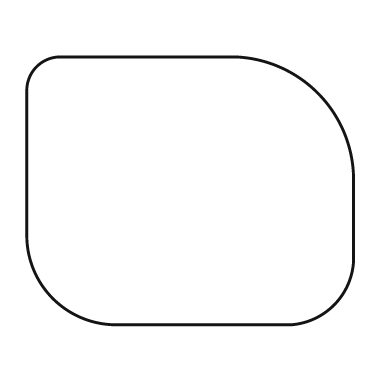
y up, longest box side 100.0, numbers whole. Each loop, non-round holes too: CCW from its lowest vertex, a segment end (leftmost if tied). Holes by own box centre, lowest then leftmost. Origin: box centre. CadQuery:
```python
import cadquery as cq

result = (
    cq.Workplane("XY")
    .moveTo(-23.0, -41.0)
    .lineTo(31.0, -41.0)
    .threePointArc((44.0, -35.0), (50.0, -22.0))
    .lineTo(50.0, 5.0)
    .threePointArc((39.0, 30.0), (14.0, 41.0))
    .lineTo(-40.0, 41.0)
    .threePointArc((-47.0, 38.0), (-50.0, 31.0))
    .lineTo(-50.0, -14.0)
    .threePointArc((-42.0, -33.0), (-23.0, -41.0))
    .close()
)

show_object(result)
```